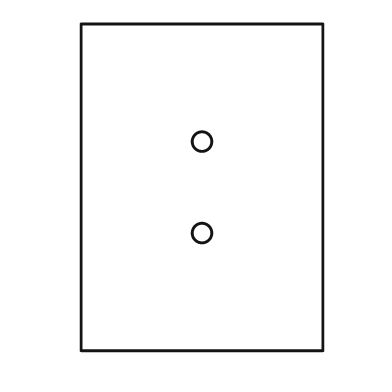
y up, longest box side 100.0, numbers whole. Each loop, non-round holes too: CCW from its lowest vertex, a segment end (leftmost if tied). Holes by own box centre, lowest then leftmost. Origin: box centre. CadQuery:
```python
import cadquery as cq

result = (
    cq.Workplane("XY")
    .moveTo(-37.0, -50.0)
    .lineTo(37.0, -50.0)
    .lineTo(37.0, 50.0)
    .lineTo(-37.0, 50.0)
    .close()
    .moveTo(0.0, -14.0)
    .circle(3.0)
    .moveTo(0.0, 14.0)
    .circle(3.0)
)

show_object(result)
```